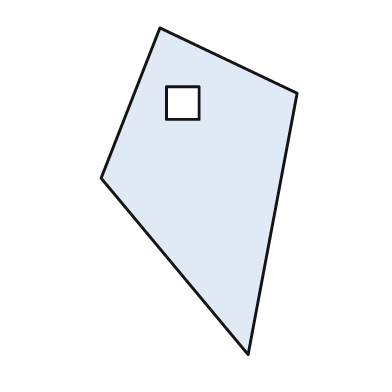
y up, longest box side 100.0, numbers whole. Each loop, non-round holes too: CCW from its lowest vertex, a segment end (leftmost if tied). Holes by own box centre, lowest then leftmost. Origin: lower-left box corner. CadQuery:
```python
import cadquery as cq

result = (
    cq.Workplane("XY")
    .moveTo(45.0, 0.0)
    .lineTo(60.0, 80.0)
    .lineTo(18.0, 100.0)
    .lineTo(0.0, 54.0)
    .close()
    .moveTo(20.0, 72.0)
    .lineTo(30.0, 72.0)
    .lineTo(30.0, 82.0)
    .lineTo(20.0, 82.0)
    .close()
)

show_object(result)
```